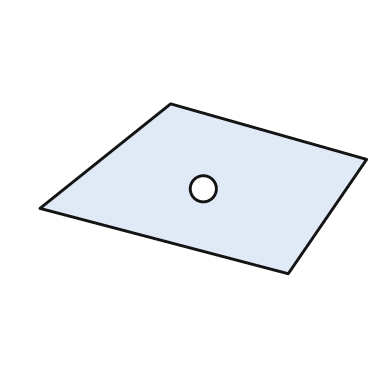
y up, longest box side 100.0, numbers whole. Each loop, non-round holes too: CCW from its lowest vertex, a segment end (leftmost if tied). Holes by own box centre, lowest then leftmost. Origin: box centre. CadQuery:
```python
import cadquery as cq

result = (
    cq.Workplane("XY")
    .moveTo(26.0, -26.0)
    .lineTo(50.0, 9.0)
    .lineTo(-10.0, 26.0)
    .lineTo(-50.0, -6.0)
    .close()
    .moveTo(0.0, 0.0)
    .circle(4.0)
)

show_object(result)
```